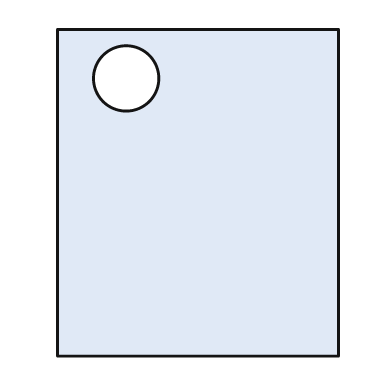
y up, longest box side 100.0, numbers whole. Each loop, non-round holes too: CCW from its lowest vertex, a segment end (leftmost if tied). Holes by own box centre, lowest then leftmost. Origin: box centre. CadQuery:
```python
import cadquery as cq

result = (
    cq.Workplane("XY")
    .moveTo(-43.0, -50.0)
    .lineTo(43.0, -50.0)
    .lineTo(43.0, 50.0)
    .lineTo(-43.0, 50.0)
    .close()
    .moveTo(-22.0, 35.0)
    .circle(10.0)
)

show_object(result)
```